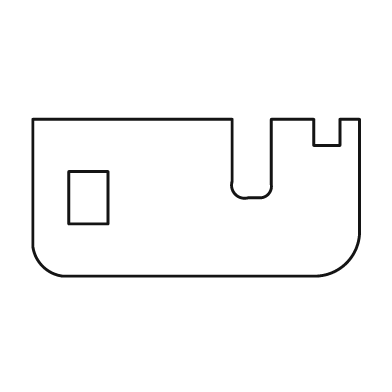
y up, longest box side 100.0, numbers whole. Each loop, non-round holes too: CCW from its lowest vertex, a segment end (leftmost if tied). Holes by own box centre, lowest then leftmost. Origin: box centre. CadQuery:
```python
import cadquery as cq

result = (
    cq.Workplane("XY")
    .moveTo(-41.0, -24.0)
    .lineTo(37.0, -24.0)
    .threePointArc((46.0, -20.0), (50.0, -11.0))
    .lineTo(50.0, 24.0)
    .lineTo(44.0, 24.0)
    .lineTo(44.0, 16.0)
    .lineTo(36.0, 16.0)
    .lineTo(36.0, 24.0)
    .lineTo(23.0, 24.0)
    .lineTo(23.0, 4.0)
    .threePointArc((22.0, 1.0), (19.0, 0.0))
    .lineTo(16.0, 0.0)
    .threePointArc((12.0, 1.0), (11.0, 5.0))
    .lineTo(11.0, 24.0)
    .lineTo(-50.0, 24.0)
    .lineTo(-50.0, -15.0)
    .threePointArc((-47.0, -21.0), (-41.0, -24.0))
    .close()
    .moveTo(-39.0, -8.0)
    .lineTo(-27.0, -8.0)
    .lineTo(-27.0, 8.0)
    .lineTo(-39.0, 8.0)
    .close()
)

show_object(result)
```